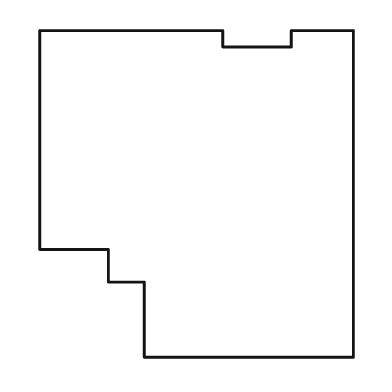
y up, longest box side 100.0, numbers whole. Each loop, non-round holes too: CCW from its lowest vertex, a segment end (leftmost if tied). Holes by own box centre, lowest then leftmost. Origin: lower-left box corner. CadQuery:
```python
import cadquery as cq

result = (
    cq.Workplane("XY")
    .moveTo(32.0, 0.0)
    .lineTo(96.0, 0.0)
    .lineTo(96.0, 100.0)
    .lineTo(77.0, 100.0)
    .lineTo(77.0, 95.0)
    .lineTo(56.0, 95.0)
    .lineTo(56.0, 100.0)
    .lineTo(0.0, 100.0)
    .lineTo(0.0, 33.0)
    .lineTo(21.0, 33.0)
    .lineTo(21.0, 23.0)
    .lineTo(32.0, 23.0)
    .close()
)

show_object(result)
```